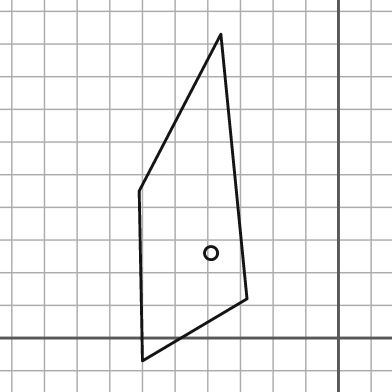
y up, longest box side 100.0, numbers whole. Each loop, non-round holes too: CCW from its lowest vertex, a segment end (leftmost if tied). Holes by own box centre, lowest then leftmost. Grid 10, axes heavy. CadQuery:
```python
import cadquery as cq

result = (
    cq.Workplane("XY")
    .moveTo(-60.0, -7.0)
    .lineTo(-28.0, 12.0)
    .lineTo(-36.0, 93.0)
    .lineTo(-61.0, 45.0)
    .close()
    .moveTo(-39.0, 26.0)
    .circle(2.0)
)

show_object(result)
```